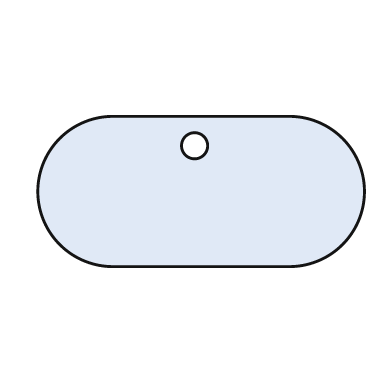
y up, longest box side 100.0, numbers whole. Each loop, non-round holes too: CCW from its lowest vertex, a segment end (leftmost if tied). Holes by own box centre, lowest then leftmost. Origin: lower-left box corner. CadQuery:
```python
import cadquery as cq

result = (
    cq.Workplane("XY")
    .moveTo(23.0, 0.0)
    .lineTo(77.0, 0.0)
    .threePointArc((100.0, 23.0), (77.0, 46.0))
    .lineTo(23.0, 46.0)
    .threePointArc((0.0, 23.0), (23.0, 0.0))
    .close()
    .moveTo(48.0, 37.0)
    .circle(4.0)
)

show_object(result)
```